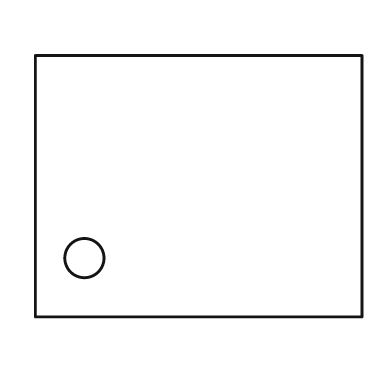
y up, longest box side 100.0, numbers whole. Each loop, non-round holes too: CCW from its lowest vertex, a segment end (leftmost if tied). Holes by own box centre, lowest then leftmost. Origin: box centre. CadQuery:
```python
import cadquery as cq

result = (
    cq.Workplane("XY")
    .moveTo(-50.0, -40.0)
    .lineTo(50.0, -40.0)
    .lineTo(50.0, 40.0)
    .lineTo(-50.0, 40.0)
    .close()
    .moveTo(-35.0, -22.0)
    .circle(6.0)
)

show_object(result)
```